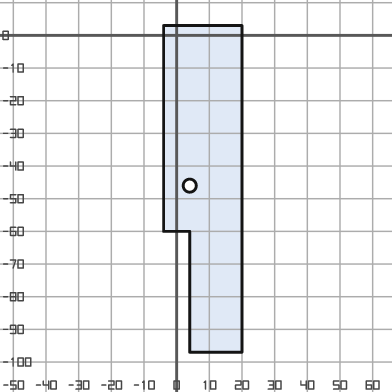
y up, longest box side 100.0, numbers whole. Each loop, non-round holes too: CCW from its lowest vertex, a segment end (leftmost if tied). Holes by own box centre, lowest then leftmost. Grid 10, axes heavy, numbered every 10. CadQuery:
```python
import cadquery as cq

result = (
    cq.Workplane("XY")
    .moveTo(4.0, -97.0)
    .lineTo(20.0, -97.0)
    .lineTo(20.0, 3.0)
    .lineTo(-4.0, 3.0)
    .lineTo(-4.0, -60.0)
    .lineTo(4.0, -60.0)
    .close()
    .moveTo(4.0, -46.0)
    .circle(2.0)
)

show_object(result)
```